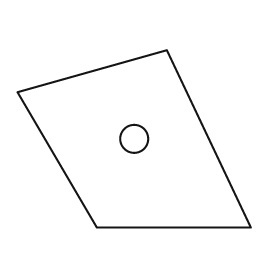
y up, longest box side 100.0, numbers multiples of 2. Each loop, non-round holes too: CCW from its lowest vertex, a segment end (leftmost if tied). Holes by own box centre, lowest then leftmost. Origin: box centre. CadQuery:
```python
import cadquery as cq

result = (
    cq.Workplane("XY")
    .moveTo(-16.0, -38.0)
    .lineTo(50.0, -38.0)
    .lineTo(14.0, 38.0)
    .lineTo(-50.0, 20.0)
    .close()
    .moveTo(0.0, 0.0)
    .circle(6.0)
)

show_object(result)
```